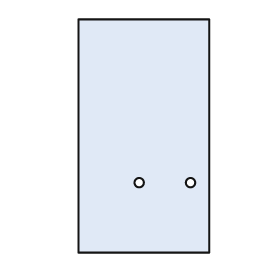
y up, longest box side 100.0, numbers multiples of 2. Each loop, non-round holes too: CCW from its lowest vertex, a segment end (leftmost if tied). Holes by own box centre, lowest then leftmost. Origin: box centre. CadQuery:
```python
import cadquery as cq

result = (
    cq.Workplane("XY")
    .moveTo(-28.0, -50.0)
    .lineTo(28.0, -50.0)
    .lineTo(28.0, 50.0)
    .lineTo(-28.0, 50.0)
    .close()
    .moveTo(-2.0, -20.0)
    .circle(2.0)
    .moveTo(20.0, -20.0)
    .circle(2.0)
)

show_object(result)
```